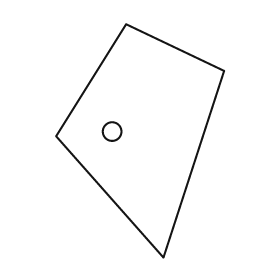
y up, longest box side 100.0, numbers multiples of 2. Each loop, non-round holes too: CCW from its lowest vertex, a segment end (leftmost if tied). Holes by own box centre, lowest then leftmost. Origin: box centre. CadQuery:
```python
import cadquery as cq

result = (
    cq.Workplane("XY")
    .moveTo(10.0, -50.0)
    .lineTo(36.0, 30.0)
    .lineTo(-6.0, 50.0)
    .lineTo(-36.0, 2.0)
    .close()
    .moveTo(-12.0, 4.0)
    .circle(4.0)
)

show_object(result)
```